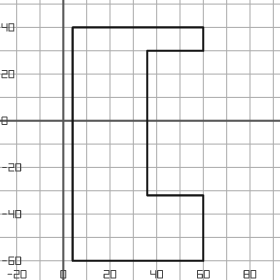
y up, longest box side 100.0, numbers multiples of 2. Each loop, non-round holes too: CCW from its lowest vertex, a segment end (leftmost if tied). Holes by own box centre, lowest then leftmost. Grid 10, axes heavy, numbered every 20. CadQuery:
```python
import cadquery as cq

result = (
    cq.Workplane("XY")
    .moveTo(4.0, -60.0)
    .lineTo(60.0, -60.0)
    .lineTo(60.0, -32.0)
    .lineTo(36.0, -32.0)
    .lineTo(36.0, 30.0)
    .lineTo(60.0, 30.0)
    .lineTo(60.0, 40.0)
    .lineTo(4.0, 40.0)
    .close()
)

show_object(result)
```